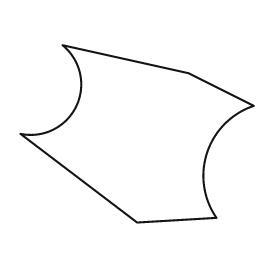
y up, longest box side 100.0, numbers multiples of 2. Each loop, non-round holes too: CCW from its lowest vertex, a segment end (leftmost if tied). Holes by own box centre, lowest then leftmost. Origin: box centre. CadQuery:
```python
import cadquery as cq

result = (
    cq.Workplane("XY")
    .moveTo(0.0, -38.0)
    .lineTo(34.0, -36.0)
    .threePointArc((30.0, -8.0), (50.0, 12.0))
    .lineTo(22.0, 26.0)
    .lineTo(-32.0, 38.0)
    .threePointArc((-26.0, 12.0), (-50.0, 0.0))
    .close()
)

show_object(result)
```